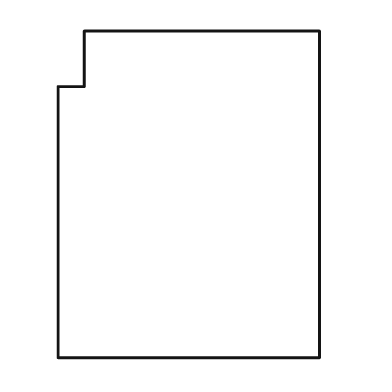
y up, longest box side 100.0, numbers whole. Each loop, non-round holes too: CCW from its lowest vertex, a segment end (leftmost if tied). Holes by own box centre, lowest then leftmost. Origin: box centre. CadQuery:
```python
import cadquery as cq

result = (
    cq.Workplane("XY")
    .moveTo(-40.0, -50.0)
    .lineTo(40.0, -50.0)
    .lineTo(40.0, 50.0)
    .lineTo(-32.0, 50.0)
    .lineTo(-32.0, 33.0)
    .lineTo(-40.0, 33.0)
    .close()
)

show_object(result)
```